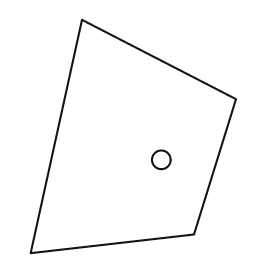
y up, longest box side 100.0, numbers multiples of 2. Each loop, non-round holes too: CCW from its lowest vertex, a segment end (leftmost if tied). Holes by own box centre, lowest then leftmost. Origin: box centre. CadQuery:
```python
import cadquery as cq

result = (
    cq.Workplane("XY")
    .moveTo(-44.0, -50.0)
    .lineTo(26.0, -42.0)
    .lineTo(44.0, 16.0)
    .lineTo(-22.0, 50.0)
    .close()
    .moveTo(12.0, -10.0)
    .circle(4.0)
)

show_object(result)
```